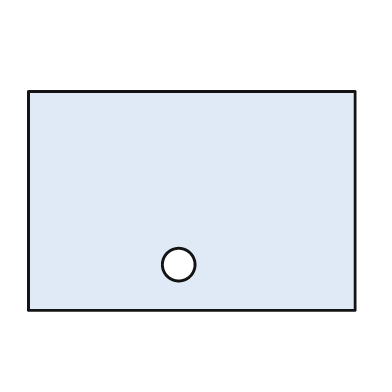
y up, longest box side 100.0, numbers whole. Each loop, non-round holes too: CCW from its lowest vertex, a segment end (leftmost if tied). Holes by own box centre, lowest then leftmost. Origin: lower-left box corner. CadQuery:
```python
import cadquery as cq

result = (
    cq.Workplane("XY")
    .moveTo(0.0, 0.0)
    .lineTo(100.0, 0.0)
    .lineTo(100.0, 67.0)
    .lineTo(0.0, 67.0)
    .close()
    .moveTo(46.0, 14.0)
    .circle(5.0)
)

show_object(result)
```